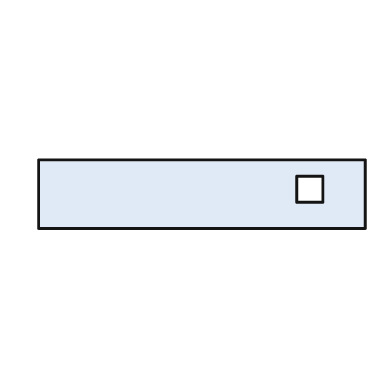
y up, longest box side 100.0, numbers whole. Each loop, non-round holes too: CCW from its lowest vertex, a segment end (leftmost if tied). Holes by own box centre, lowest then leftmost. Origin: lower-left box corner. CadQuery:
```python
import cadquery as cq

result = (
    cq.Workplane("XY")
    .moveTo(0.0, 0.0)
    .lineTo(100.0, 0.0)
    .lineTo(100.0, 21.0)
    .lineTo(0.0, 21.0)
    .close()
    .moveTo(79.0, 8.0)
    .lineTo(87.0, 8.0)
    .lineTo(87.0, 16.0)
    .lineTo(79.0, 16.0)
    .close()
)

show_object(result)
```